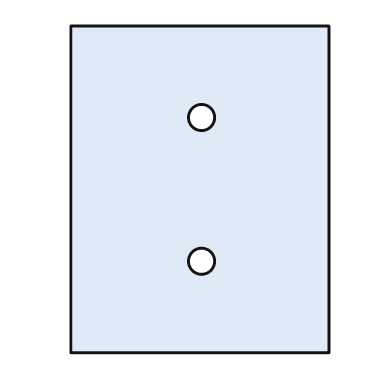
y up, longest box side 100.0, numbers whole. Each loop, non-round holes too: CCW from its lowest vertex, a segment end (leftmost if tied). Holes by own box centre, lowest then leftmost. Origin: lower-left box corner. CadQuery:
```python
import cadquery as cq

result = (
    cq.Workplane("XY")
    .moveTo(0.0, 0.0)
    .lineTo(79.0, 0.0)
    .lineTo(79.0, 100.0)
    .lineTo(0.0, 100.0)
    .close()
    .moveTo(40.0, 28.0)
    .circle(4.0)
    .moveTo(40.0, 72.0)
    .circle(4.0)
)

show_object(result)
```